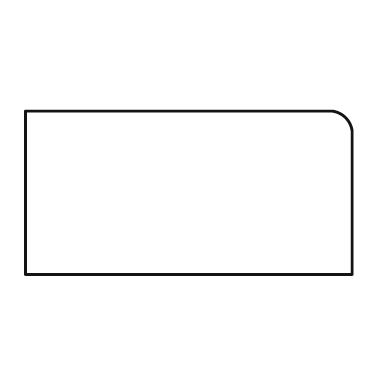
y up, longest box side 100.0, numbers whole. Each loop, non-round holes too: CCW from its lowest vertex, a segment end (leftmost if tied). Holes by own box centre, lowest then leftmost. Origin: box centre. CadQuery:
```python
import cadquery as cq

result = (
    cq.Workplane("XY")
    .moveTo(-50.0, -25.0)
    .lineTo(50.0, -25.0)
    .lineTo(50.0, 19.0)
    .threePointArc((48.0, 23.0), (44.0, 25.0))
    .lineTo(-50.0, 25.0)
    .close()
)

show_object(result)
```